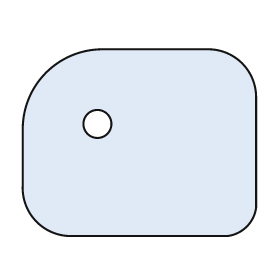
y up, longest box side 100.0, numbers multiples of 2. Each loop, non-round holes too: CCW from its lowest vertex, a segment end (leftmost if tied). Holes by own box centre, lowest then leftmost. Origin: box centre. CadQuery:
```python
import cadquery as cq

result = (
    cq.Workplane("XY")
    .moveTo(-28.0, -40.0)
    .lineTo(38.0, -40.0)
    .threePointArc((46.0, -36.0), (50.0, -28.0))
    .lineTo(50.0, 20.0)
    .threePointArc((44.0, 34.0), (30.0, 40.0))
    .lineTo(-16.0, 40.0)
    .threePointArc((-40.0, 30.0), (-50.0, 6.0))
    .lineTo(-50.0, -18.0)
    .threePointArc((-44.0, -34.0), (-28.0, -40.0))
    .close()
    .moveTo(-18.0, 8.0)
    .circle(6.0)
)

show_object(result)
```